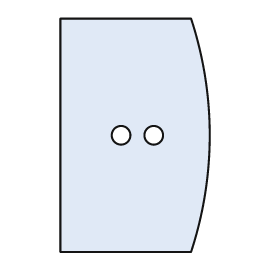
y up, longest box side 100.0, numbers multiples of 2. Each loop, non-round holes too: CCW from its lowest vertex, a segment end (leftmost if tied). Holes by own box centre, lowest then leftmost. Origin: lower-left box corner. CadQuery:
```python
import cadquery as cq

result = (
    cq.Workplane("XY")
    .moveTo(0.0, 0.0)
    .lineTo(56.0, 0.0)
    .threePointArc((64.0, 50.0), (56.0, 100.0))
    .lineTo(0.0, 100.0)
    .close()
    .moveTo(26.0, 50.0)
    .circle(4.0)
    .moveTo(40.0, 50.0)
    .circle(4.0)
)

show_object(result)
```